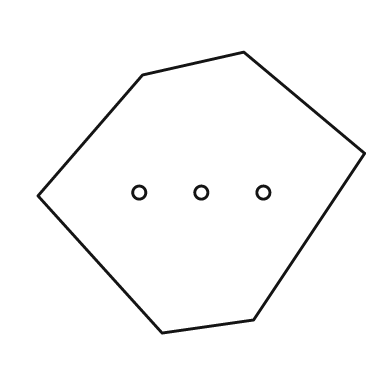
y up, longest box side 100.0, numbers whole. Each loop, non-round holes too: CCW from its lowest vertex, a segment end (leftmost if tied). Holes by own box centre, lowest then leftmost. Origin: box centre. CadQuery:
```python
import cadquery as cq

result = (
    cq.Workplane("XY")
    .moveTo(-12.0, -43.0)
    .lineTo(16.0, -39.0)
    .lineTo(50.0, 12.0)
    .lineTo(13.0, 43.0)
    .lineTo(-18.0, 36.0)
    .lineTo(-50.0, -1.0)
    .close()
    .moveTo(-19.0, 0.0)
    .circle(2.0)
    .moveTo(0.0, 0.0)
    .circle(2.0)
    .moveTo(19.0, 0.0)
    .circle(2.0)
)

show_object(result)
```